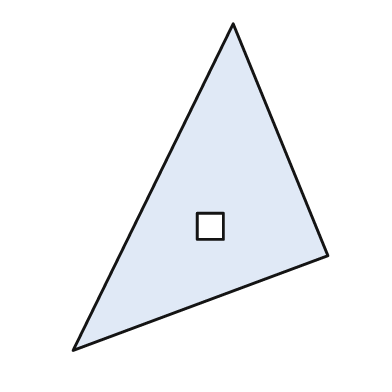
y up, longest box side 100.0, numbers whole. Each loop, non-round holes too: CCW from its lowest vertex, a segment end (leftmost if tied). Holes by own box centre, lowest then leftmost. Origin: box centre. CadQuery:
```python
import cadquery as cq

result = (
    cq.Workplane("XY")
    .moveTo(-39.0, -50.0)
    .lineTo(39.0, -21.0)
    .lineTo(10.0, 50.0)
    .close()
    .moveTo(-1.0, -16.0)
    .lineTo(7.0, -16.0)
    .lineTo(7.0, -8.0)
    .lineTo(-1.0, -8.0)
    .close()
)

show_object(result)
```